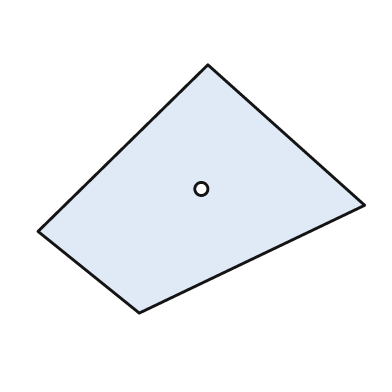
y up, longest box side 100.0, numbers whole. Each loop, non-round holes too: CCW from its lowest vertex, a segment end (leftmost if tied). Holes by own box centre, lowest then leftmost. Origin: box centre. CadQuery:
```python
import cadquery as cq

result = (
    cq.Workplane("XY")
    .moveTo(-19.0, -38.0)
    .lineTo(50.0, -5.0)
    .lineTo(2.0, 38.0)
    .lineTo(-50.0, -13.0)
    .close()
    .moveTo(0.0, 0.0)
    .circle(2.0)
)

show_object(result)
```